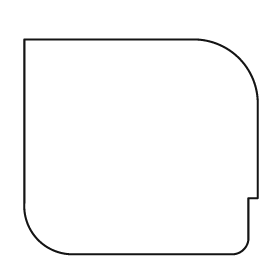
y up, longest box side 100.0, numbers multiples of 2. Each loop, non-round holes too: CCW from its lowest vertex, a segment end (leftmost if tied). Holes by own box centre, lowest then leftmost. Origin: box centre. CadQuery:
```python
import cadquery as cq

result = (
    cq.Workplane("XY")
    .moveTo(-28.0, -46.0)
    .lineTo(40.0, -46.0)
    .threePointArc((44.0, -44.0), (46.0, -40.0))
    .lineTo(46.0, -22.0)
    .lineTo(50.0, -22.0)
    .lineTo(50.0, 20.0)
    .threePointArc((42.0, 38.0), (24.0, 46.0))
    .lineTo(-50.0, 46.0)
    .lineTo(-50.0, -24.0)
    .threePointArc((-44.0, -40.0), (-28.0, -46.0))
    .close()
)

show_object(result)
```